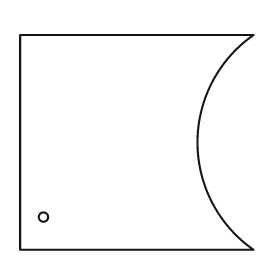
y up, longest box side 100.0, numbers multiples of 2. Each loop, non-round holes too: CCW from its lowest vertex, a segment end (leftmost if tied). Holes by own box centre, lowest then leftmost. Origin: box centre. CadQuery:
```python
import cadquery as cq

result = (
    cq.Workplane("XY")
    .moveTo(-50.0, -46.0)
    .lineTo(50.0, -46.0)
    .threePointArc((26.0, 0.0), (50.0, 46.0))
    .lineTo(-50.0, 46.0)
    .close()
    .moveTo(-40.0, -32.0)
    .circle(2.0)
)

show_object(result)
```